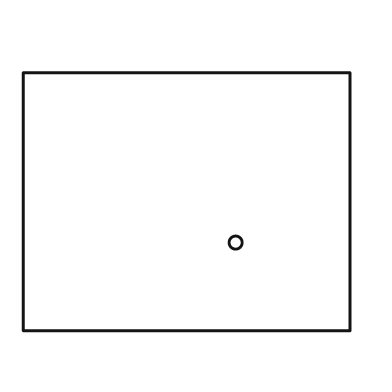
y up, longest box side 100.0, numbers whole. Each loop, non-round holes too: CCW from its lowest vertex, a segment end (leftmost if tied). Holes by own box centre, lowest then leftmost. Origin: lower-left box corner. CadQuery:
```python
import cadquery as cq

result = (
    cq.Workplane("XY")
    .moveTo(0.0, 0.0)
    .lineTo(100.0, 0.0)
    .lineTo(100.0, 79.0)
    .lineTo(0.0, 79.0)
    .close()
    .moveTo(65.0, 27.0)
    .circle(2.0)
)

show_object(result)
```